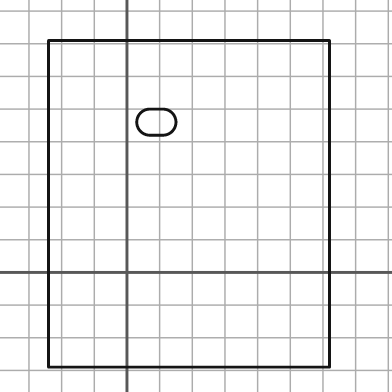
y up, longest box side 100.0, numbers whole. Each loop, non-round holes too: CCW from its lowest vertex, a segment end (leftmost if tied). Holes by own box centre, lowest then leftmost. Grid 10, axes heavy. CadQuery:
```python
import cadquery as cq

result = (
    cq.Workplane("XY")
    .moveTo(-24.0, -29.0)
    .lineTo(62.0, -29.0)
    .lineTo(62.0, 71.0)
    .lineTo(-24.0, 71.0)
    .close()
    .moveTo(7.0, 42.0)
    .lineTo(11.0, 42.0)
    .threePointArc((15.0, 46.0), (11.0, 50.0))
    .lineTo(7.0, 50.0)
    .threePointArc((3.0, 46.0), (7.0, 42.0))
    .close()
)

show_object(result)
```